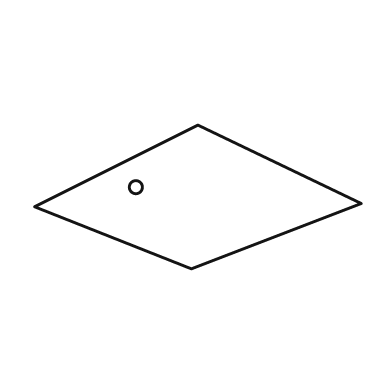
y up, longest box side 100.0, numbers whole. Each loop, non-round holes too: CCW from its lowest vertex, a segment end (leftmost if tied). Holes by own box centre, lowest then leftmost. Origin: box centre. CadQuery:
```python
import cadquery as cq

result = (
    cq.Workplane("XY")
    .moveTo(-2.0, -22.0)
    .lineTo(50.0, -2.0)
    .lineTo(0.0, 22.0)
    .lineTo(-50.0, -3.0)
    .close()
    .moveTo(-19.0, 3.0)
    .circle(2.0)
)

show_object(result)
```